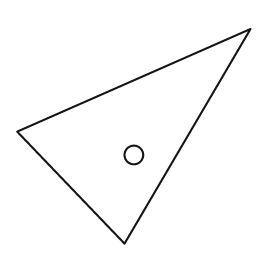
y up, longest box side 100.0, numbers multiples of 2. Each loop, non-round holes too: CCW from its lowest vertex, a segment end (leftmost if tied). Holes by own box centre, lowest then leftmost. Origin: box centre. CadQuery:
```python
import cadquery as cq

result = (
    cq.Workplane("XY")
    .moveTo(-4.0, -46.0)
    .lineTo(50.0, 46.0)
    .lineTo(-50.0, 2.0)
    .close()
    .moveTo(0.0, -8.0)
    .circle(4.0)
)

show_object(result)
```